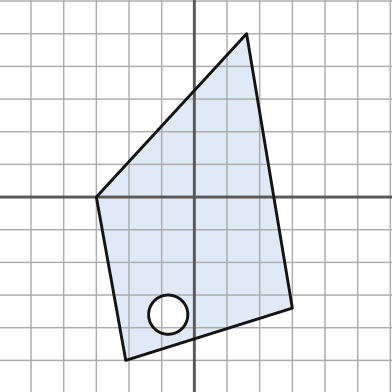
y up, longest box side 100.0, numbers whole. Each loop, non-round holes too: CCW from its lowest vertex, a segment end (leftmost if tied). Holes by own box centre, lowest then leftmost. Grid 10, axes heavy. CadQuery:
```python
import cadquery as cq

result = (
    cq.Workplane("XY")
    .moveTo(-21.0, -50.0)
    .lineTo(30.0, -34.0)
    .lineTo(16.0, 50.0)
    .lineTo(-30.0, 0.0)
    .close()
    .moveTo(-8.0, -36.0)
    .circle(6.0)
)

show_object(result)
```